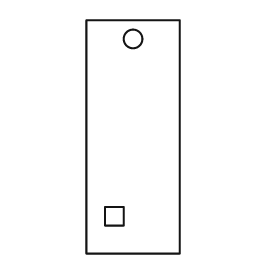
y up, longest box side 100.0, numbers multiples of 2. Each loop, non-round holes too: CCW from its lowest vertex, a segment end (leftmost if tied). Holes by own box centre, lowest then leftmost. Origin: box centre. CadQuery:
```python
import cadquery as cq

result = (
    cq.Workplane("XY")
    .moveTo(-20.0, -50.0)
    .lineTo(20.0, -50.0)
    .lineTo(20.0, 50.0)
    .lineTo(-20.0, 50.0)
    .close()
    .moveTo(-12.0, -38.0)
    .lineTo(-4.0, -38.0)
    .lineTo(-4.0, -30.0)
    .lineTo(-12.0, -30.0)
    .close()
    .moveTo(0.0, 42.0)
    .circle(4.0)
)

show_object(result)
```